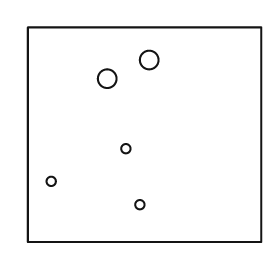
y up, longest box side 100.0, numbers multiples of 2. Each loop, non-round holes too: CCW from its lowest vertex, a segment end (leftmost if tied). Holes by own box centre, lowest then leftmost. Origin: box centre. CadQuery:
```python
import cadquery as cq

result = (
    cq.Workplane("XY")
    .moveTo(-50.0, -46.0)
    .lineTo(50.0, -46.0)
    .lineTo(50.0, 46.0)
    .lineTo(-50.0, 46.0)
    .close()
    .moveTo(-2.0, -30.0)
    .circle(2.0)
    .moveTo(-40.0, -20.0)
    .circle(2.0)
    .moveTo(-8.0, -6.0)
    .circle(2.0)
    .moveTo(-16.0, 24.0)
    .circle(4.0)
    .moveTo(2.0, 32.0)
    .circle(4.0)
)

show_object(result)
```